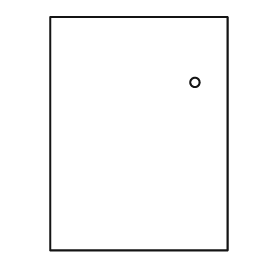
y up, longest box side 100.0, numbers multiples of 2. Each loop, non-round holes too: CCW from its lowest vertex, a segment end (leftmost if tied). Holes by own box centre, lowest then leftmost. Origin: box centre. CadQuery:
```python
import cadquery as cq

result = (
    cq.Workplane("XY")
    .moveTo(-38.0, -50.0)
    .lineTo(38.0, -50.0)
    .lineTo(38.0, 50.0)
    .lineTo(-38.0, 50.0)
    .close()
    .moveTo(24.0, 22.0)
    .circle(2.0)
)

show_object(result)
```